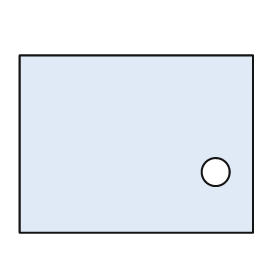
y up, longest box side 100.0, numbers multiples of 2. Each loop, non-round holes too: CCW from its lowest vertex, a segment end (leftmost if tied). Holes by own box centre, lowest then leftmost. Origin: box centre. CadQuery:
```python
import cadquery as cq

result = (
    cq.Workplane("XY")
    .moveTo(-50.0, -38.0)
    .lineTo(50.0, -38.0)
    .lineTo(50.0, 38.0)
    .lineTo(-50.0, 38.0)
    .close()
    .moveTo(34.0, -12.0)
    .circle(6.0)
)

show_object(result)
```